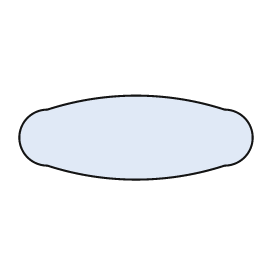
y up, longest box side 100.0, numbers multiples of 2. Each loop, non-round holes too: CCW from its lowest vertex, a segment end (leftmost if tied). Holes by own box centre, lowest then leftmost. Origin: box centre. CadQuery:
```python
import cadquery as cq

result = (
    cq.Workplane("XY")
    .moveTo(-38.0, -12.0)
    .threePointArc((0.0, -18.0), (38.0, -12.0))
    .threePointArc((50.0, 0.0), (38.0, 12.0))
    .threePointArc((0.0, 18.0), (-38.0, 12.0))
    .threePointArc((-50.0, 0.0), (-38.0, -12.0))
    .close()
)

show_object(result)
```